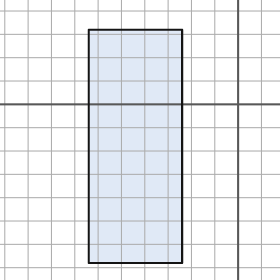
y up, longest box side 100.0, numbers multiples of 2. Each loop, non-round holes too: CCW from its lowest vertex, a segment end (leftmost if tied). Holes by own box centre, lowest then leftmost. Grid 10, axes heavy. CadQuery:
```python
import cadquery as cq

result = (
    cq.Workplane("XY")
    .moveTo(-64.0, -68.0)
    .lineTo(-24.0, -68.0)
    .lineTo(-24.0, 32.0)
    .lineTo(-64.0, 32.0)
    .close()
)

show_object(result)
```